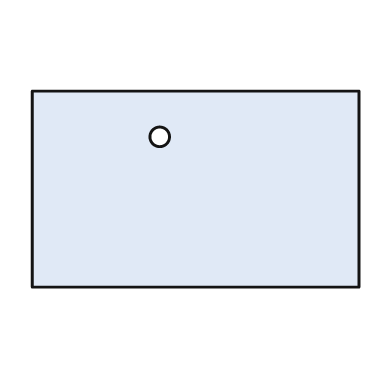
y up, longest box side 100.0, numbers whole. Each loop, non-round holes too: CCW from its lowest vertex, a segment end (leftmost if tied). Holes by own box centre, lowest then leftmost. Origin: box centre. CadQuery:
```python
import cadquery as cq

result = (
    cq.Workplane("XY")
    .moveTo(-50.0, -30.0)
    .lineTo(50.0, -30.0)
    .lineTo(50.0, 30.0)
    .lineTo(-50.0, 30.0)
    .close()
    .moveTo(-11.0, 16.0)
    .circle(3.0)
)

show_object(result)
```